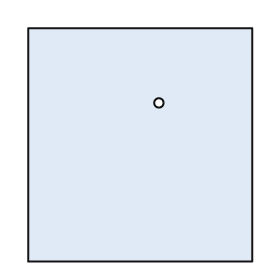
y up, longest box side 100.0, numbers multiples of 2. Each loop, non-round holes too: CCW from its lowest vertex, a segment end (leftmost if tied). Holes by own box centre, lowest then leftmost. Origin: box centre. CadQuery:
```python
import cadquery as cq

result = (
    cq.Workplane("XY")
    .moveTo(-48.0, -50.0)
    .lineTo(48.0, -50.0)
    .lineTo(48.0, 50.0)
    .lineTo(-48.0, 50.0)
    .close()
    .moveTo(8.0, 18.0)
    .circle(2.0)
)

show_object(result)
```